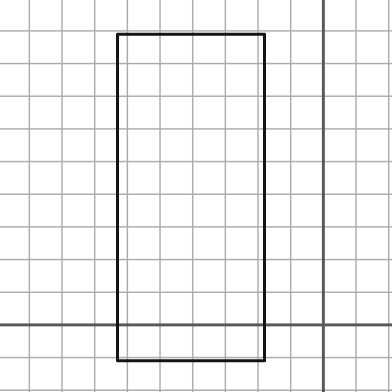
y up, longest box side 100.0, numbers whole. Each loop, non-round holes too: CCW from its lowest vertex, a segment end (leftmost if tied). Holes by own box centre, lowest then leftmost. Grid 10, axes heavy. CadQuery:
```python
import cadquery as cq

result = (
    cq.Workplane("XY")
    .moveTo(-63.0, -11.0)
    .lineTo(-18.0, -11.0)
    .lineTo(-18.0, 89.0)
    .lineTo(-63.0, 89.0)
    .close()
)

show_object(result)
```